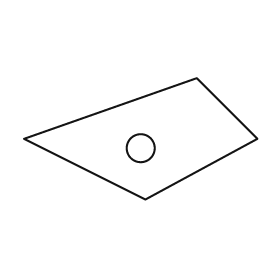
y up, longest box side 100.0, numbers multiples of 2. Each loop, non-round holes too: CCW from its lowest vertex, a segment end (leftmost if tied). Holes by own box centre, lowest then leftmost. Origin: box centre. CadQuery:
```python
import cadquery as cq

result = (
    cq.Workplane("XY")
    .moveTo(2.0, -26.0)
    .lineTo(50.0, 0.0)
    .lineTo(24.0, 26.0)
    .lineTo(-50.0, 0.0)
    .close()
    .moveTo(0.0, -4.0)
    .circle(6.0)
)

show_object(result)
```